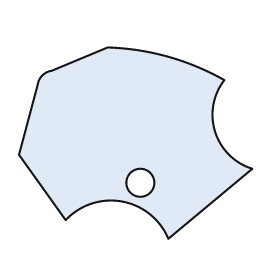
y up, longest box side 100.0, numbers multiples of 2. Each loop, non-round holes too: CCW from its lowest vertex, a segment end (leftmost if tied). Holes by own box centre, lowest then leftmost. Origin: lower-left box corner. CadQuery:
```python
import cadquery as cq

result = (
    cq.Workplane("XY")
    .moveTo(64.0, 0.0)
    .lineTo(100.0, 30.0)
    .threePointArc((84.0, 46.0), (88.0, 68.0))
    .threePointArc((64.0, 78.0), (38.0, 82.0))
    .lineTo(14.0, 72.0)
    .threePointArc((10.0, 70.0), (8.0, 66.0))
    .lineTo(0.0, 36.0)
    .lineTo(20.0, 8.0)
    .threePointArc((44.0, 16.0), (64.0, 0.0))
    .close()
    .moveTo(52.0, 24.0)
    .circle(6.0)
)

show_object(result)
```